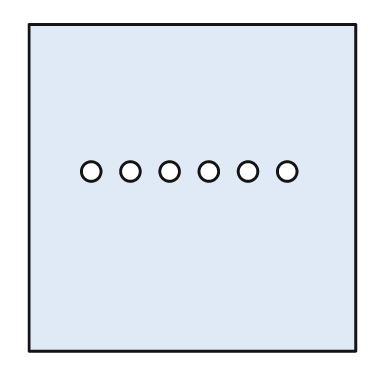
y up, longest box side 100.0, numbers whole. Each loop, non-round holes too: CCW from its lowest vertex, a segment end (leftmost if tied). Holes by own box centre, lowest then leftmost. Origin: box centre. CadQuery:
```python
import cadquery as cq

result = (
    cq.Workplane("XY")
    .moveTo(-50.0, -50.0)
    .lineTo(50.0, -50.0)
    .lineTo(50.0, 50.0)
    .lineTo(-50.0, 50.0)
    .close()
    .moveTo(-31.0, 5.0)
    .circle(3.0)
    .moveTo(-19.0, 5.0)
    .circle(3.0)
    .moveTo(-7.0, 5.0)
    .circle(3.0)
    .moveTo(5.0, 5.0)
    .circle(3.0)
    .moveTo(17.0, 5.0)
    .circle(3.0)
    .moveTo(29.0, 5.0)
    .circle(3.0)
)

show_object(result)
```